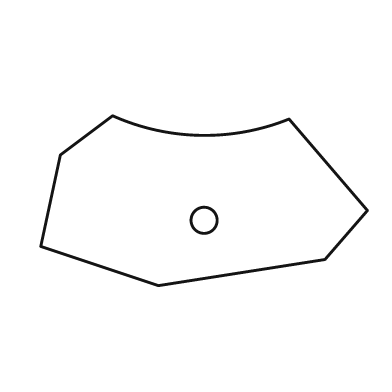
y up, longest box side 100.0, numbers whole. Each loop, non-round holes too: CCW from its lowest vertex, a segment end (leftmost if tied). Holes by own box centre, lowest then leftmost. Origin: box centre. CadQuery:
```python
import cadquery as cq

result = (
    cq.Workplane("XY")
    .moveTo(-14.0, -26.0)
    .lineTo(37.0, -18.0)
    .lineTo(50.0, -3.0)
    .lineTo(26.0, 25.0)
    .threePointArc((-1.0, 20.0), (-28.0, 26.0))
    .lineTo(-44.0, 14.0)
    .lineTo(-50.0, -14.0)
    .close()
    .moveTo(0.0, -6.0)
    .circle(4.0)
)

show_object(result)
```